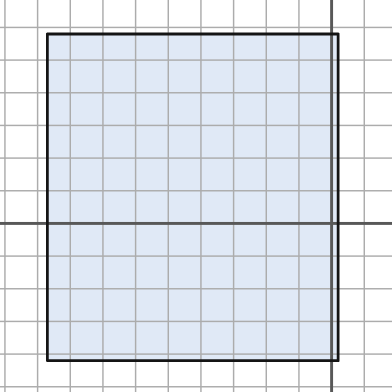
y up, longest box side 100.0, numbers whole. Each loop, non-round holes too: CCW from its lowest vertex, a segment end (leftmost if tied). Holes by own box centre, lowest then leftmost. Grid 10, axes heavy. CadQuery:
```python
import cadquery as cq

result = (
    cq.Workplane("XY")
    .moveTo(-87.0, -42.0)
    .lineTo(2.0, -42.0)
    .lineTo(2.0, 58.0)
    .lineTo(-87.0, 58.0)
    .close()
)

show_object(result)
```